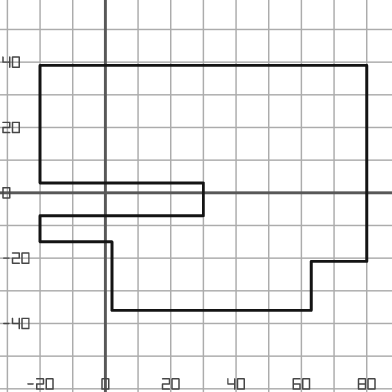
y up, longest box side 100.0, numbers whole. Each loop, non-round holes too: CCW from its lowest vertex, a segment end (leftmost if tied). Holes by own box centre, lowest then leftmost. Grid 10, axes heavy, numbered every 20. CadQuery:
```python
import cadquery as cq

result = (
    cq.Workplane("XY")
    .moveTo(2.0, -36.0)
    .lineTo(63.0, -36.0)
    .lineTo(63.0, -21.0)
    .lineTo(80.0, -21.0)
    .lineTo(80.0, 39.0)
    .lineTo(-20.0, 39.0)
    .lineTo(-20.0, 3.0)
    .lineTo(30.0, 3.0)
    .lineTo(30.0, -7.0)
    .lineTo(-20.0, -7.0)
    .lineTo(-20.0, -15.0)
    .lineTo(2.0, -15.0)
    .close()
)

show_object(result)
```